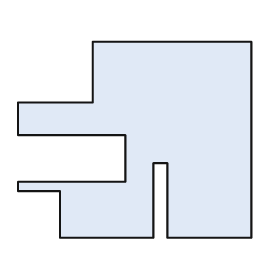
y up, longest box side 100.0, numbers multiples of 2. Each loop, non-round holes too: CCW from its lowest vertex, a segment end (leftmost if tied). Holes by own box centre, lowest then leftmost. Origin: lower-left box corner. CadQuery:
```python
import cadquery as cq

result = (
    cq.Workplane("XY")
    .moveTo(18.0, 0.0)
    .lineTo(58.0, 0.0)
    .lineTo(58.0, 32.0)
    .lineTo(64.0, 32.0)
    .lineTo(64.0, 0.0)
    .lineTo(100.0, 0.0)
    .lineTo(100.0, 84.0)
    .lineTo(32.0, 84.0)
    .lineTo(32.0, 58.0)
    .lineTo(0.0, 58.0)
    .lineTo(0.0, 44.0)
    .lineTo(46.0, 44.0)
    .lineTo(46.0, 24.0)
    .lineTo(0.0, 24.0)
    .lineTo(0.0, 20.0)
    .lineTo(18.0, 20.0)
    .close()
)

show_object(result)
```